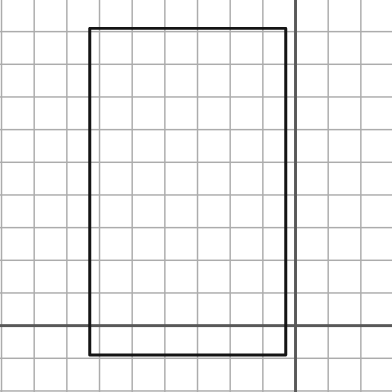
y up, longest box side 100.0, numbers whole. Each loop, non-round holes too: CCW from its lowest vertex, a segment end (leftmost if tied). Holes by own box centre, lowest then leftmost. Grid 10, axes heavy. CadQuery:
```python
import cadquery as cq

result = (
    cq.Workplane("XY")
    .moveTo(-63.0, -9.0)
    .lineTo(-3.0, -9.0)
    .lineTo(-3.0, 91.0)
    .lineTo(-63.0, 91.0)
    .close()
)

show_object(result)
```